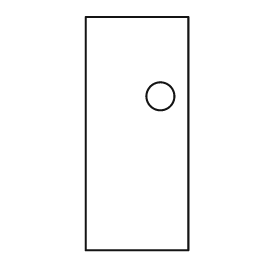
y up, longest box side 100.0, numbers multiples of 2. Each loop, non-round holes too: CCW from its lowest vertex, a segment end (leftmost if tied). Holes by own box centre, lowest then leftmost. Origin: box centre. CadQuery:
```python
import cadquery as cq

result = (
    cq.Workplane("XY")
    .moveTo(-22.0, -50.0)
    .lineTo(22.0, -50.0)
    .lineTo(22.0, 50.0)
    .lineTo(-22.0, 50.0)
    .close()
    .moveTo(10.0, 16.0)
    .circle(6.0)
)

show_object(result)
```